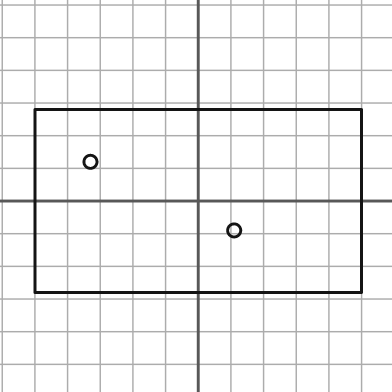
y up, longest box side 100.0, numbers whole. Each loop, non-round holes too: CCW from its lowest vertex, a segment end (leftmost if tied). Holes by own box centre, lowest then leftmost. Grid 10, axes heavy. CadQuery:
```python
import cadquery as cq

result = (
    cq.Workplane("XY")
    .moveTo(-50.0, -28.0)
    .lineTo(50.0, -28.0)
    .lineTo(50.0, 28.0)
    .lineTo(-50.0, 28.0)
    .close()
    .moveTo(11.0, -9.0)
    .circle(2.0)
    .moveTo(-33.0, 12.0)
    .circle(2.0)
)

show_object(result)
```